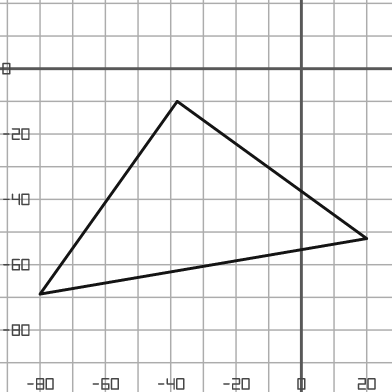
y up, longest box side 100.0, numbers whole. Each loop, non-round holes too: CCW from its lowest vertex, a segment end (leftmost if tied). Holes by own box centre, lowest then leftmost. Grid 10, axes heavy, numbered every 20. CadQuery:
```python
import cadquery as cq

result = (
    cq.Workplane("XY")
    .moveTo(-80.0, -69.0)
    .lineTo(20.0, -52.0)
    .lineTo(-38.0, -10.0)
    .close()
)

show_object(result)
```